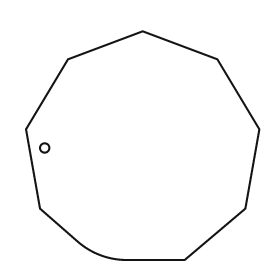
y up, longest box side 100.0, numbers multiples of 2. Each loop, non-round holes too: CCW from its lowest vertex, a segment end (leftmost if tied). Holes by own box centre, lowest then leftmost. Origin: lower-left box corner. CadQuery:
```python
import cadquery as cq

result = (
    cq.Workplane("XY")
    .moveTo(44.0, 0.0)
    .lineTo(68.0, 0.0)
    .lineTo(94.0, 22.0)
    .lineTo(100.0, 56.0)
    .lineTo(82.0, 86.0)
    .lineTo(50.0, 98.0)
    .lineTo(18.0, 86.0)
    .lineTo(0.0, 56.0)
    .lineTo(6.0, 22.0)
    .lineTo(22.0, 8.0)
    .threePointArc((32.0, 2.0), (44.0, 0.0))
    .close()
    .moveTo(8.0, 48.0)
    .circle(2.0)
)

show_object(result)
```